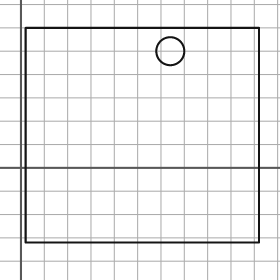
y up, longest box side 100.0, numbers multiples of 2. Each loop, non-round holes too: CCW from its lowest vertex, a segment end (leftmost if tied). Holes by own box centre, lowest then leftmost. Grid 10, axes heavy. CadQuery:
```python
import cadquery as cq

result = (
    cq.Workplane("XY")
    .moveTo(2.0, -32.0)
    .lineTo(102.0, -32.0)
    .lineTo(102.0, 60.0)
    .lineTo(2.0, 60.0)
    .close()
    .moveTo(64.0, 50.0)
    .circle(6.0)
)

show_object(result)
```